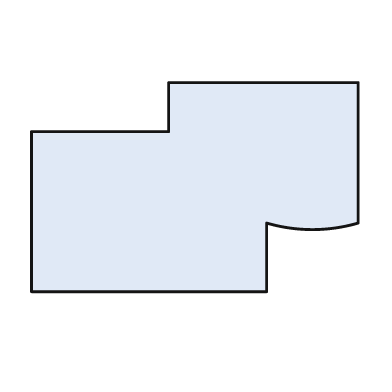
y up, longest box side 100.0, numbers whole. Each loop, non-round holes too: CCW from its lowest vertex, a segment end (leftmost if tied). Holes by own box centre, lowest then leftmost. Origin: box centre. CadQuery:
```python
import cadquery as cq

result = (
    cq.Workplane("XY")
    .moveTo(-50.0, -32.0)
    .lineTo(22.0, -32.0)
    .lineTo(22.0, -11.0)
    .threePointArc((36.0, -13.0), (50.0, -11.0))
    .lineTo(50.0, 32.0)
    .lineTo(-8.0, 32.0)
    .lineTo(-8.0, 17.0)
    .lineTo(-50.0, 17.0)
    .close()
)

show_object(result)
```